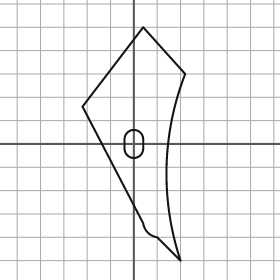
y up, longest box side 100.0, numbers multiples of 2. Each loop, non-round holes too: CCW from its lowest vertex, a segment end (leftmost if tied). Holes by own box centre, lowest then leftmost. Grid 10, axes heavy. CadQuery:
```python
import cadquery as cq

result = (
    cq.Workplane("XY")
    .moveTo(20.0, -50.0)
    .threePointArc((14.0, -10.0), (22.0, 30.0))
    .lineTo(4.0, 50.0)
    .lineTo(-22.0, 16.0)
    .lineTo(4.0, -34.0)
    .threePointArc((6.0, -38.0), (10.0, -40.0))
    .close()
    .moveTo(-4.0, -2.0)
    .threePointArc((0.0, -6.0), (4.0, -2.0))
    .lineTo(4.0, 2.0)
    .threePointArc((0.0, 6.0), (-4.0, 2.0))
    .close()
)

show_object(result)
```